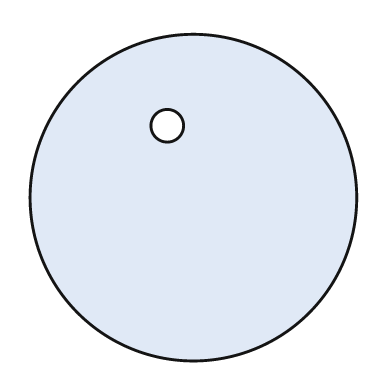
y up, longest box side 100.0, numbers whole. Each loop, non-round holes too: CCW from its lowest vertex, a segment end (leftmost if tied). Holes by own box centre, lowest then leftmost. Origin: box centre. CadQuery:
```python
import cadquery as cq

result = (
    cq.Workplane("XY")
    .moveTo(0.0, 0.0)
    .circle(50.0)
    .moveTo(-8.0, 22.0)
    .circle(5.0)
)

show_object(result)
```